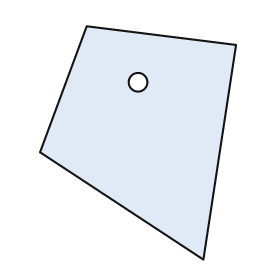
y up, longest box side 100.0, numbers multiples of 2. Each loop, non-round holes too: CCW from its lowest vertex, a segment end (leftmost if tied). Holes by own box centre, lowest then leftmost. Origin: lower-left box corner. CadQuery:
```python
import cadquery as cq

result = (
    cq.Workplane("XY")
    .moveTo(70.0, 0.0)
    .lineTo(84.0, 92.0)
    .lineTo(20.0, 100.0)
    .lineTo(0.0, 46.0)
    .close()
    .moveTo(42.0, 76.0)
    .circle(4.0)
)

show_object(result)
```